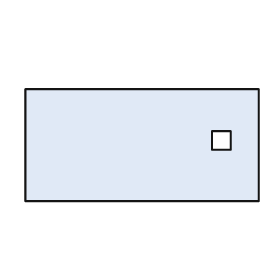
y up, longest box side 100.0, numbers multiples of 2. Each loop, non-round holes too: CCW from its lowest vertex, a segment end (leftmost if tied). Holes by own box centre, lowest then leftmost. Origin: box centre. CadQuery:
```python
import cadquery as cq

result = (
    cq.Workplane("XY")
    .moveTo(-50.0, -24.0)
    .lineTo(50.0, -24.0)
    .lineTo(50.0, 24.0)
    .lineTo(-50.0, 24.0)
    .close()
    .moveTo(30.0, -2.0)
    .lineTo(38.0, -2.0)
    .lineTo(38.0, 6.0)
    .lineTo(30.0, 6.0)
    .close()
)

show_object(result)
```